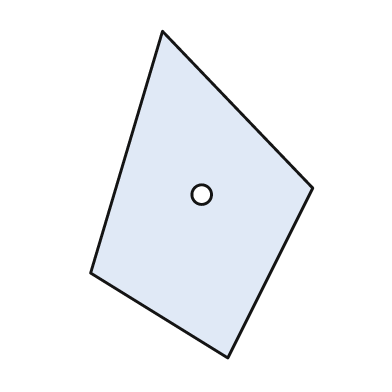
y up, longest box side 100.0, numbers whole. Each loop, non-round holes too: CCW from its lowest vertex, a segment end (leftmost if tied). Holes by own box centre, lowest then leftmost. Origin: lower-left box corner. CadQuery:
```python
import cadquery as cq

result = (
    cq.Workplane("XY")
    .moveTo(42.0, 0.0)
    .lineTo(68.0, 52.0)
    .lineTo(22.0, 100.0)
    .lineTo(0.0, 26.0)
    .close()
    .moveTo(34.0, 50.0)
    .circle(3.0)
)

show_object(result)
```